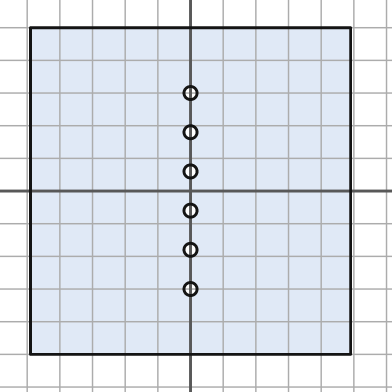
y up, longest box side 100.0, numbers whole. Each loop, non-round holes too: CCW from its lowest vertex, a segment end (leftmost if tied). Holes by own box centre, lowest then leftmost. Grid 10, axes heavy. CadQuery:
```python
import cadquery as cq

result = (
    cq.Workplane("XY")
    .moveTo(-49.0, -50.0)
    .lineTo(49.0, -50.0)
    .lineTo(49.0, 50.0)
    .lineTo(-49.0, 50.0)
    .close()
    .moveTo(0.0, -30.0)
    .circle(2.0)
    .moveTo(0.0, -18.0)
    .circle(2.0)
    .moveTo(0.0, -6.0)
    .circle(2.0)
    .moveTo(0.0, 6.0)
    .circle(2.0)
    .moveTo(0.0, 18.0)
    .circle(2.0)
    .moveTo(0.0, 30.0)
    .circle(2.0)
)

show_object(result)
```